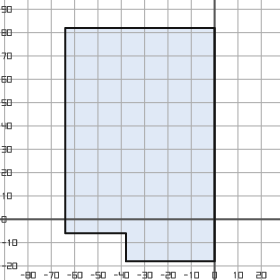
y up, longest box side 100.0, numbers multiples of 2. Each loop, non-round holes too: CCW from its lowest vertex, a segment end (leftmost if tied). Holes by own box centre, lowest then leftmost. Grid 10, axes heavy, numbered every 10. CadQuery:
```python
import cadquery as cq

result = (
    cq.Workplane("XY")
    .moveTo(-38.0, -18.0)
    .lineTo(0.0, -18.0)
    .lineTo(0.0, 82.0)
    .lineTo(-64.0, 82.0)
    .lineTo(-64.0, -6.0)
    .lineTo(-38.0, -6.0)
    .close()
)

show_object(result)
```